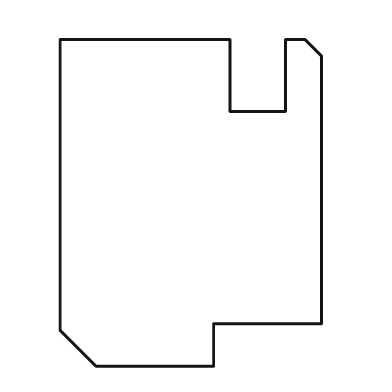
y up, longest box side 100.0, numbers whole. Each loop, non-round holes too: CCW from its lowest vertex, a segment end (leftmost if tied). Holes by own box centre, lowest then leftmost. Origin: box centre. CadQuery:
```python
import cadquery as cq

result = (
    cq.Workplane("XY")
    .moveTo(-29.0, -50.0)
    .lineTo(7.0, -50.0)
    .lineTo(7.0, -37.0)
    .lineTo(40.0, -37.0)
    .lineTo(40.0, 45.0)
    .lineTo(35.0, 50.0)
    .lineTo(29.0, 50.0)
    .lineTo(29.0, 28.0)
    .lineTo(12.0, 28.0)
    .lineTo(12.0, 50.0)
    .lineTo(-40.0, 50.0)
    .lineTo(-40.0, -39.0)
    .close()
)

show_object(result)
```